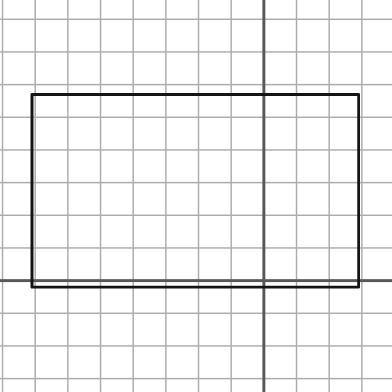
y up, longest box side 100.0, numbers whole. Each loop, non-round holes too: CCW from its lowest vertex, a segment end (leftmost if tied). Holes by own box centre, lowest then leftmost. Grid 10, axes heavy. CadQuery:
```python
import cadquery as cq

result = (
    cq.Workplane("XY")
    .moveTo(-71.0, -2.0)
    .lineTo(29.0, -2.0)
    .lineTo(29.0, 57.0)
    .lineTo(-71.0, 57.0)
    .close()
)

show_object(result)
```